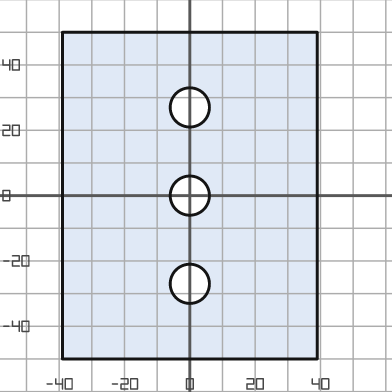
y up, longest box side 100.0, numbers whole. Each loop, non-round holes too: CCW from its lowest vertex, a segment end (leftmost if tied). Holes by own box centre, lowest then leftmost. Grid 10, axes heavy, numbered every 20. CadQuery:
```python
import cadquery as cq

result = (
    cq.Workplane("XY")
    .moveTo(-39.0, -50.0)
    .lineTo(39.0, -50.0)
    .lineTo(39.0, 50.0)
    .lineTo(-39.0, 50.0)
    .close()
    .moveTo(0.0, -27.0)
    .circle(6.0)
    .moveTo(0.0, 0.0)
    .circle(6.0)
    .moveTo(0.0, 27.0)
    .circle(6.0)
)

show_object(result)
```